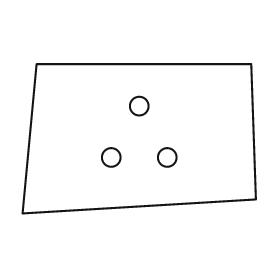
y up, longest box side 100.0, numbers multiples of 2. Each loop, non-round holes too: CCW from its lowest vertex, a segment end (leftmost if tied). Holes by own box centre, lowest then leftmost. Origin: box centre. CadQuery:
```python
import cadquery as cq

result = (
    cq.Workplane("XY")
    .moveTo(-50.0, -32.0)
    .lineTo(50.0, -26.0)
    .lineTo(48.0, 32.0)
    .lineTo(-44.0, 32.0)
    .close()
    .moveTo(-12.0, -8.0)
    .circle(4.0)
    .moveTo(12.0, -8.0)
    .circle(4.0)
    .moveTo(0.0, 14.0)
    .circle(4.0)
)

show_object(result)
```